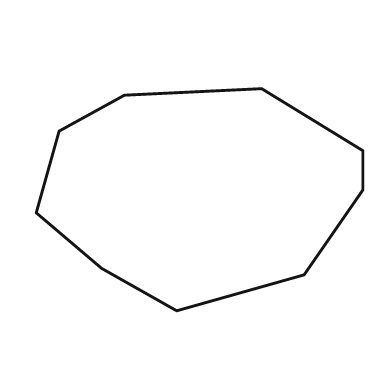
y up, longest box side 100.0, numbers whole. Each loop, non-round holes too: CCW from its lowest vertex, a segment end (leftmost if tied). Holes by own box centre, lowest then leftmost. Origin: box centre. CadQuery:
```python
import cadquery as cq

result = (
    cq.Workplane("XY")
    .moveTo(-7.0, -34.0)
    .lineTo(32.0, -23.0)
    .lineTo(50.0, 3.0)
    .lineTo(50.0, 15.0)
    .lineTo(19.0, 34.0)
    .lineTo(-23.0, 32.0)
    .lineTo(-43.0, 21.0)
    .lineTo(-50.0, -4.0)
    .lineTo(-30.0, -21.0)
    .close()
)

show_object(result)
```